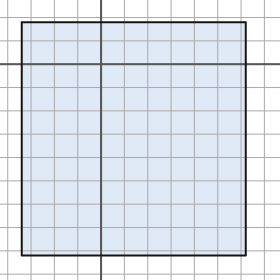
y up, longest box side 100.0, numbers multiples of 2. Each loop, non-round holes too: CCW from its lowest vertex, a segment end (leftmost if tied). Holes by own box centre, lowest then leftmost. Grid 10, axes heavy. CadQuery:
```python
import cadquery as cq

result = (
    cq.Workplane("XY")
    .moveTo(-34.0, -82.0)
    .lineTo(62.0, -82.0)
    .lineTo(62.0, 18.0)
    .lineTo(-34.0, 18.0)
    .close()
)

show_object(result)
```